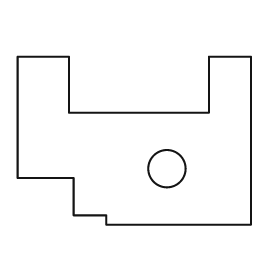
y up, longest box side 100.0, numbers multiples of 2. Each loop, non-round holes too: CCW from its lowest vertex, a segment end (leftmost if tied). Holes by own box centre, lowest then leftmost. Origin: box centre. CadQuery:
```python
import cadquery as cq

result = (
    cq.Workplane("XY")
    .moveTo(-12.0, -36.0)
    .lineTo(50.0, -36.0)
    .lineTo(50.0, 36.0)
    .lineTo(32.0, 36.0)
    .lineTo(32.0, 12.0)
    .lineTo(-28.0, 12.0)
    .lineTo(-28.0, 36.0)
    .lineTo(-50.0, 36.0)
    .lineTo(-50.0, -16.0)
    .lineTo(-26.0, -16.0)
    .lineTo(-26.0, -32.0)
    .lineTo(-12.0, -32.0)
    .close()
    .moveTo(14.0, -12.0)
    .circle(8.0)
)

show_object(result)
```